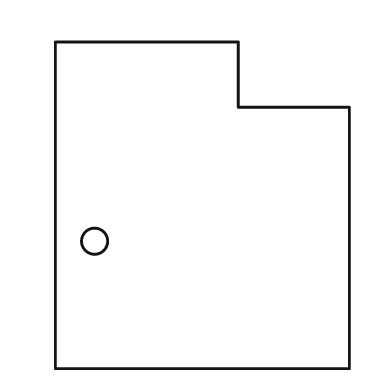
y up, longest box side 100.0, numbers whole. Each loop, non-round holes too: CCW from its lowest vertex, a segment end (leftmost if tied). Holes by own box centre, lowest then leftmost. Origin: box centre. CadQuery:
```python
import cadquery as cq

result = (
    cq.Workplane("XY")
    .moveTo(-45.0, -50.0)
    .lineTo(45.0, -50.0)
    .lineTo(45.0, 30.0)
    .lineTo(11.0, 30.0)
    .lineTo(11.0, 50.0)
    .lineTo(-45.0, 50.0)
    .close()
    .moveTo(-33.0, -11.0)
    .circle(4.0)
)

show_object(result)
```